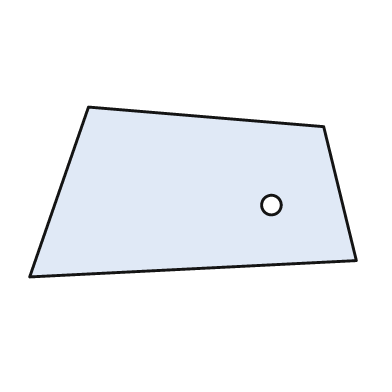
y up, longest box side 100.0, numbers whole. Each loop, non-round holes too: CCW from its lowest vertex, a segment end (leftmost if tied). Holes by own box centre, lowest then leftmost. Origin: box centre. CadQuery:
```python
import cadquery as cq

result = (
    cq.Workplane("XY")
    .moveTo(-50.0, -26.0)
    .lineTo(50.0, -21.0)
    .lineTo(40.0, 20.0)
    .lineTo(-32.0, 26.0)
    .close()
    .moveTo(24.0, -4.0)
    .circle(3.0)
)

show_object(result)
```